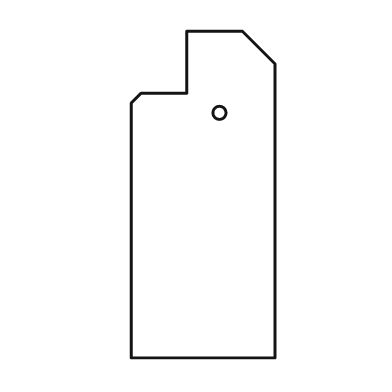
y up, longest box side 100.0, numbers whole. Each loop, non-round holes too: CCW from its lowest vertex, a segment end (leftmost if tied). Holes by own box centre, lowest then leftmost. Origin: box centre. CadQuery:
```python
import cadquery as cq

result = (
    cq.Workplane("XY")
    .moveTo(-22.0, -50.0)
    .lineTo(22.0, -50.0)
    .lineTo(22.0, 40.0)
    .lineTo(12.0, 50.0)
    .lineTo(-5.0, 50.0)
    .lineTo(-5.0, 31.0)
    .lineTo(-19.0, 31.0)
    .lineTo(-22.0, 28.0)
    .close()
    .moveTo(5.0, 25.0)
    .circle(2.0)
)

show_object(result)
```